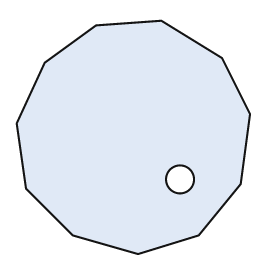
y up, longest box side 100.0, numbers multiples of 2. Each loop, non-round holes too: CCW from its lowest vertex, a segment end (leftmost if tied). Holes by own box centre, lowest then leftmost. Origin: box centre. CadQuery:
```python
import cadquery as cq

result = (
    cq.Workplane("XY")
    .moveTo(2.0, -50.0)
    .lineTo(28.0, -42.0)
    .lineTo(46.0, -20.0)
    .lineTo(50.0, 10.0)
    .lineTo(38.0, 34.0)
    .lineTo(12.0, 50.0)
    .lineTo(-16.0, 48.0)
    .lineTo(-38.0, 32.0)
    .lineTo(-50.0, 6.0)
    .lineTo(-46.0, -22.0)
    .lineTo(-26.0, -42.0)
    .close()
    .moveTo(20.0, -18.0)
    .circle(6.0)
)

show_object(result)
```